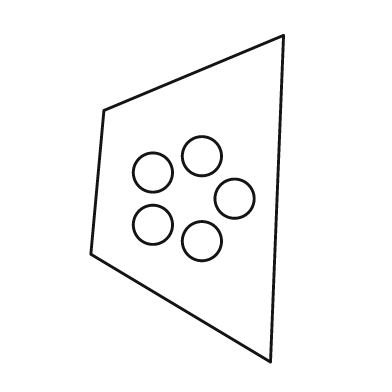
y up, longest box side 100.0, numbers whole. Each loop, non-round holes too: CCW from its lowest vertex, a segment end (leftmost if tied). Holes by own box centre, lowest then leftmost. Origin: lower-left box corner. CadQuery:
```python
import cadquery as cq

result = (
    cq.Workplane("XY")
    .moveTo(55.0, 0.0)
    .lineTo(59.0, 100.0)
    .lineTo(4.0, 77.0)
    .lineTo(0.0, 33.0)
    .close()
    .moveTo(34.0, 37.0)
    .circle(6.0)
    .moveTo(19.0, 42.0)
    .circle(6.0)
    .moveTo(44.0, 50.0)
    .circle(6.0)
    .moveTo(19.0, 58.0)
    .circle(6.0)
    .moveTo(34.0, 63.0)
    .circle(6.0)
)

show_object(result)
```